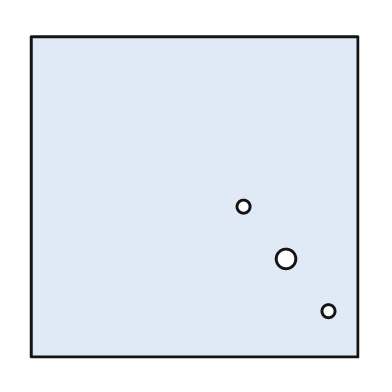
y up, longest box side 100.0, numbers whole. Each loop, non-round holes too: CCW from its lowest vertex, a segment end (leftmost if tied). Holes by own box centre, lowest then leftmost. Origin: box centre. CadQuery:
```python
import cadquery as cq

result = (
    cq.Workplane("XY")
    .moveTo(-50.0, -49.0)
    .lineTo(50.0, -49.0)
    .lineTo(50.0, 49.0)
    .lineTo(-50.0, 49.0)
    .close()
    .moveTo(41.0, -35.0)
    .circle(2.0)
    .moveTo(28.0, -19.0)
    .circle(3.0)
    .moveTo(15.0, -3.0)
    .circle(2.0)
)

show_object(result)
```